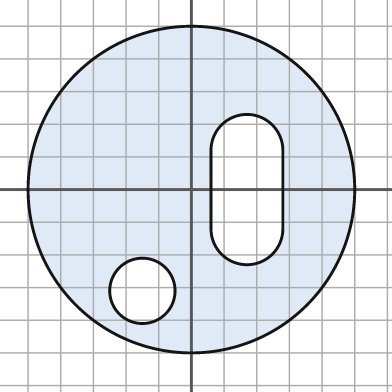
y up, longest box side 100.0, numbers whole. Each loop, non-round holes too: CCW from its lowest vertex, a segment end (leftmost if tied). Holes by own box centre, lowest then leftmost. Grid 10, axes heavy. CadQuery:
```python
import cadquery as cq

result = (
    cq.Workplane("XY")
    .moveTo(0.0, 0.0)
    .circle(50.0)
    .moveTo(-15.0, -31.0)
    .circle(10.0)
    .moveTo(6.0, -12.0)
    .threePointArc((17.0, -23.0), (28.0, -12.0))
    .lineTo(28.0, 12.0)
    .threePointArc((17.0, 23.0), (6.0, 12.0))
    .close()
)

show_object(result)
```